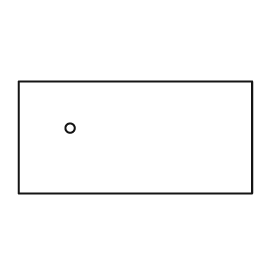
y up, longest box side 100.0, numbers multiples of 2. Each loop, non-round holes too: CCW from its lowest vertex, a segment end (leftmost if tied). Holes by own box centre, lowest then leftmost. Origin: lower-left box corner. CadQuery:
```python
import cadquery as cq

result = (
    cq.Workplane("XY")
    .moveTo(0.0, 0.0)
    .lineTo(100.0, 0.0)
    .lineTo(100.0, 48.0)
    .lineTo(0.0, 48.0)
    .close()
    .moveTo(22.0, 28.0)
    .circle(2.0)
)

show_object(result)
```